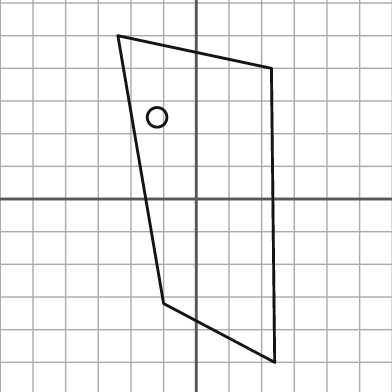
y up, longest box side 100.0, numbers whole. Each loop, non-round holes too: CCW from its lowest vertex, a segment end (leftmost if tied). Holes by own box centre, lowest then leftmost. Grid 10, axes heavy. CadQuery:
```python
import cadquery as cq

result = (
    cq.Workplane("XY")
    .moveTo(24.0, -50.0)
    .lineTo(23.0, 40.0)
    .lineTo(-24.0, 50.0)
    .lineTo(-10.0, -32.0)
    .close()
    .moveTo(-12.0, 25.0)
    .circle(3.0)
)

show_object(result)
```